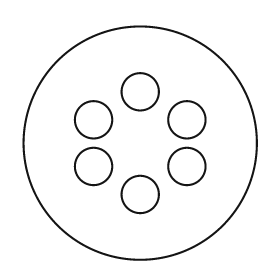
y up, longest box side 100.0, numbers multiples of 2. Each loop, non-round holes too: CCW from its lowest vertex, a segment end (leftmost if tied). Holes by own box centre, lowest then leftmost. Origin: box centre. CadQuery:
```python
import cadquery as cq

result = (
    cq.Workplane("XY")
    .moveTo(0.0, 0.0)
    .circle(50.0)
    .moveTo(0.0, -22.0)
    .circle(8.0)
    .moveTo(-20.0, -10.0)
    .circle(8.0)
    .moveTo(20.0, -10.0)
    .circle(8.0)
    .moveTo(-20.0, 10.0)
    .circle(8.0)
    .moveTo(20.0, 10.0)
    .circle(8.0)
    .moveTo(0.0, 22.0)
    .circle(8.0)
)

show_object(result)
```